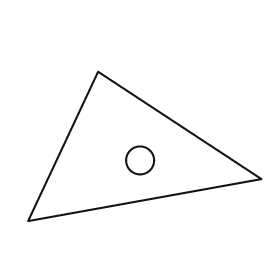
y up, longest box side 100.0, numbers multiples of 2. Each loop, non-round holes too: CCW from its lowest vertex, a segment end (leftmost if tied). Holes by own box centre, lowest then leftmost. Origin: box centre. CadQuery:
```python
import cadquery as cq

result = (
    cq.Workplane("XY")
    .moveTo(-50.0, -32.0)
    .lineTo(50.0, -14.0)
    .lineTo(-20.0, 32.0)
    .close()
    .moveTo(-2.0, -6.0)
    .circle(6.0)
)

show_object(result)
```